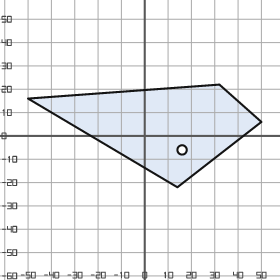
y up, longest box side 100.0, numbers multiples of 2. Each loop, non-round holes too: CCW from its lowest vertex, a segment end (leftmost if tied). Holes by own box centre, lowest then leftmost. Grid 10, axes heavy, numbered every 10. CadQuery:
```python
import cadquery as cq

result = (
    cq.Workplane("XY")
    .moveTo(14.0, -22.0)
    .lineTo(50.0, 6.0)
    .lineTo(32.0, 22.0)
    .lineTo(-50.0, 16.0)
    .close()
    .moveTo(16.0, -6.0)
    .circle(2.0)
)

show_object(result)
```